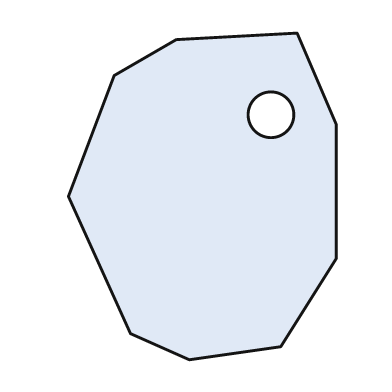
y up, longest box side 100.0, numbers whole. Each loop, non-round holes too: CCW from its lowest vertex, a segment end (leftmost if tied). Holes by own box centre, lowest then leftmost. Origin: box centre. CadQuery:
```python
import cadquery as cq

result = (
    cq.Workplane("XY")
    .moveTo(-4.0, -50.0)
    .lineTo(24.0, -46.0)
    .lineTo(41.0, -19.0)
    .lineTo(41.0, 22.0)
    .lineTo(29.0, 50.0)
    .lineTo(-8.0, 48.0)
    .lineTo(-27.0, 37.0)
    .lineTo(-41.0, 0.0)
    .lineTo(-22.0, -42.0)
    .close()
    .moveTo(21.0, 25.0)
    .circle(7.0)
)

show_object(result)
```